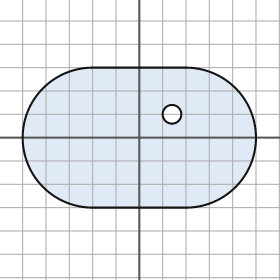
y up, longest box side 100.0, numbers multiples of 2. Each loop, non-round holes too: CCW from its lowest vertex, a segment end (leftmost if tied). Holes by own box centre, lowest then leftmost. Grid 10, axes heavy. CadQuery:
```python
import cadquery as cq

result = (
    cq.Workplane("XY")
    .moveTo(-20.0, -30.0)
    .lineTo(20.0, -30.0)
    .threePointArc((50.0, 0.0), (20.0, 30.0))
    .lineTo(-20.0, 30.0)
    .threePointArc((-50.0, 0.0), (-20.0, -30.0))
    .close()
    .moveTo(14.0, 10.0)
    .circle(4.0)
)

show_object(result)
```